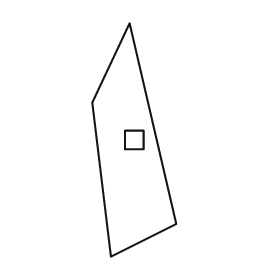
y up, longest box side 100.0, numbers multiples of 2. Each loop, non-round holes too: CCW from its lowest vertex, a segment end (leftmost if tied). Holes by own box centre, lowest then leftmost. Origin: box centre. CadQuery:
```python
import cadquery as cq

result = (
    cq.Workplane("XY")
    .moveTo(-10.0, -50.0)
    .lineTo(18.0, -36.0)
    .lineTo(-2.0, 50.0)
    .lineTo(-18.0, 16.0)
    .close()
    .moveTo(-4.0, -4.0)
    .lineTo(4.0, -4.0)
    .lineTo(4.0, 4.0)
    .lineTo(-4.0, 4.0)
    .close()
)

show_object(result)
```